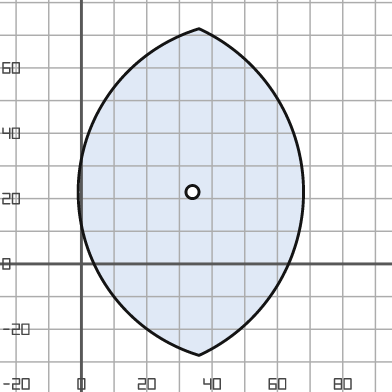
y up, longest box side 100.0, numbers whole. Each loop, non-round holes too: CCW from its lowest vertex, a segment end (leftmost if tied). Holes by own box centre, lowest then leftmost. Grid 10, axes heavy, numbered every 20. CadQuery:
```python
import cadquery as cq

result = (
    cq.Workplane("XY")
    .moveTo(36.0, -28.0)
    .threePointArc((68.0, 22.0), (36.0, 72.0))
    .threePointArc((-1.0, 22.0), (36.0, -28.0))
    .close()
    .moveTo(34.0, 22.0)
    .circle(2.0)
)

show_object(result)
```